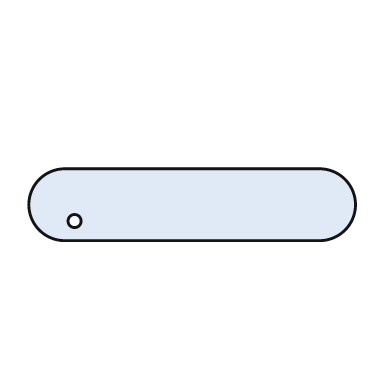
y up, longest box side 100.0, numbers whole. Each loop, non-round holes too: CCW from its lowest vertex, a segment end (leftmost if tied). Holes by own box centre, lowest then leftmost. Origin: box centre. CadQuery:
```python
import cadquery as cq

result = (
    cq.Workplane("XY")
    .moveTo(-39.0, -11.0)
    .lineTo(39.0, -11.0)
    .threePointArc((50.0, 0.0), (39.0, 11.0))
    .lineTo(-39.0, 11.0)
    .threePointArc((-50.0, 0.0), (-39.0, -11.0))
    .close()
    .moveTo(-36.0, -5.0)
    .circle(2.0)
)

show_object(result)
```